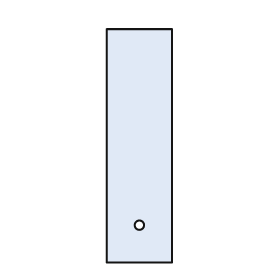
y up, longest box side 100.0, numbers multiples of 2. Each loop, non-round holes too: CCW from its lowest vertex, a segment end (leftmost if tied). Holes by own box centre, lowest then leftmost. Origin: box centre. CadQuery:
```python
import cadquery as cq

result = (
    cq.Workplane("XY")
    .moveTo(-14.0, -50.0)
    .lineTo(14.0, -50.0)
    .lineTo(14.0, 50.0)
    .lineTo(-14.0, 50.0)
    .close()
    .moveTo(0.0, -34.0)
    .circle(2.0)
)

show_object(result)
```